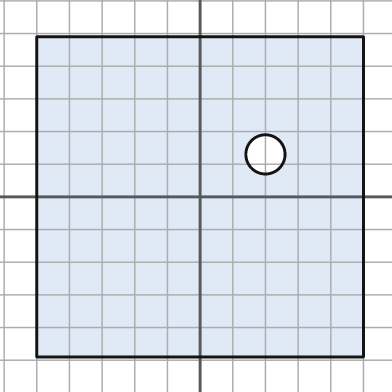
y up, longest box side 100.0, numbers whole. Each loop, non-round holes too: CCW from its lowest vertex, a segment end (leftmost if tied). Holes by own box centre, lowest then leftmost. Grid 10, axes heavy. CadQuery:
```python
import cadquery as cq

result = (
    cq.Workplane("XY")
    .moveTo(-50.0, -49.0)
    .lineTo(50.0, -49.0)
    .lineTo(50.0, 49.0)
    .lineTo(-50.0, 49.0)
    .close()
    .moveTo(20.0, 13.0)
    .circle(6.0)
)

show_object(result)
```